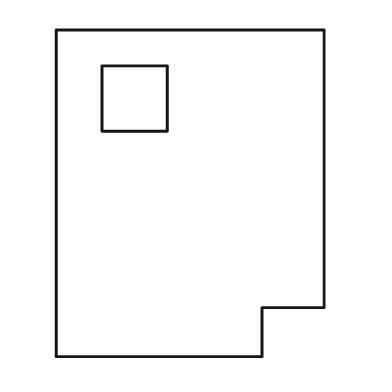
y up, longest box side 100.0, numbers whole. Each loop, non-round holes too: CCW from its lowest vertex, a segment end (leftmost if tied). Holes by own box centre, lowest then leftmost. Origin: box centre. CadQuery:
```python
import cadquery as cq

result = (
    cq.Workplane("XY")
    .moveTo(-41.0, -50.0)
    .lineTo(22.0, -50.0)
    .lineTo(22.0, -35.0)
    .lineTo(41.0, -35.0)
    .lineTo(41.0, 50.0)
    .lineTo(-41.0, 50.0)
    .close()
    .moveTo(-27.0, 19.0)
    .lineTo(-7.0, 19.0)
    .lineTo(-7.0, 39.0)
    .lineTo(-27.0, 39.0)
    .close()
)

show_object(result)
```